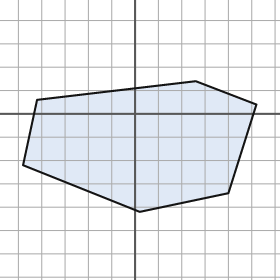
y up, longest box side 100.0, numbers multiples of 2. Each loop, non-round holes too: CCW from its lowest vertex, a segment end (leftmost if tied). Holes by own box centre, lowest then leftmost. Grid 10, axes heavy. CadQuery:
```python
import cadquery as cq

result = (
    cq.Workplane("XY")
    .moveTo(2.0, -42.0)
    .lineTo(40.0, -34.0)
    .lineTo(52.0, 4.0)
    .lineTo(26.0, 14.0)
    .lineTo(-42.0, 6.0)
    .lineTo(-48.0, -22.0)
    .close()
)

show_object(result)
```